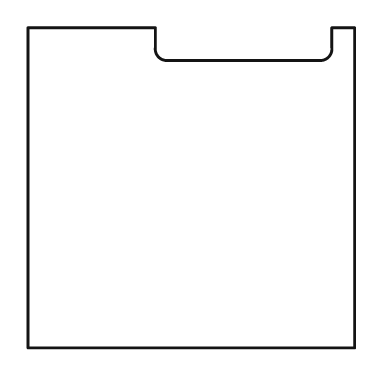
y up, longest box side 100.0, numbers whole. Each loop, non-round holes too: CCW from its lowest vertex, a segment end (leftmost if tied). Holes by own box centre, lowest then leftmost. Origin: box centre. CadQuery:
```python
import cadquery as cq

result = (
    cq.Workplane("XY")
    .moveTo(-50.0, -49.0)
    .lineTo(50.0, -49.0)
    .lineTo(50.0, 49.0)
    .lineTo(43.0, 49.0)
    .lineTo(43.0, 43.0)
    .threePointArc((42.0, 40.0), (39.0, 39.0))
    .lineTo(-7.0, 39.0)
    .threePointArc((-10.0, 40.0), (-11.0, 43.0))
    .lineTo(-11.0, 49.0)
    .lineTo(-50.0, 49.0)
    .close()
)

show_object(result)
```